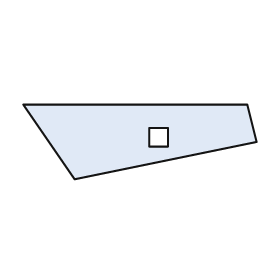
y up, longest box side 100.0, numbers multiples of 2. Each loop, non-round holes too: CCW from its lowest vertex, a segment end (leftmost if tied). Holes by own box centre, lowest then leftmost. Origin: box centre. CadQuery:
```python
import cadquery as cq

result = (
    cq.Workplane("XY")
    .moveTo(-28.0, -16.0)
    .lineTo(50.0, 0.0)
    .lineTo(46.0, 16.0)
    .lineTo(-50.0, 16.0)
    .close()
    .moveTo(4.0, -2.0)
    .lineTo(12.0, -2.0)
    .lineTo(12.0, 6.0)
    .lineTo(4.0, 6.0)
    .close()
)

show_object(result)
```